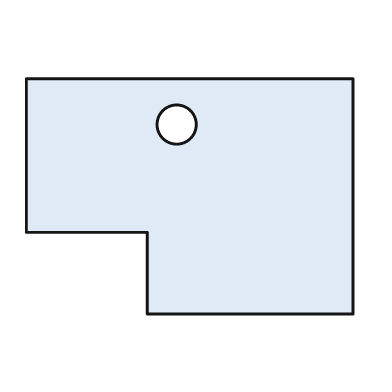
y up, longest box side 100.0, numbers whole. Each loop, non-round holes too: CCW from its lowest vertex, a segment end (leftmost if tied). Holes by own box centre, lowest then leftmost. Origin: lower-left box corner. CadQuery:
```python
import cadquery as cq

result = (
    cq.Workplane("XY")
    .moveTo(37.0, 0.0)
    .lineTo(100.0, 0.0)
    .lineTo(100.0, 72.0)
    .lineTo(0.0, 72.0)
    .lineTo(0.0, 25.0)
    .lineTo(37.0, 25.0)
    .close()
    .moveTo(46.0, 58.0)
    .circle(6.0)
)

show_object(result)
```